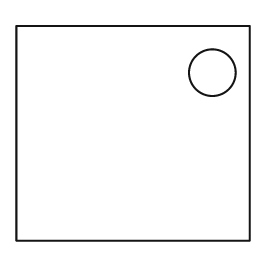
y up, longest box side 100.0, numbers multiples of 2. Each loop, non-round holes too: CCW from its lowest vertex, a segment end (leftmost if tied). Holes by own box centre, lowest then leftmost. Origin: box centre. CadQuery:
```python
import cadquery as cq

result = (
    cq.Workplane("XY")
    .moveTo(-50.0, -46.0)
    .lineTo(50.0, -46.0)
    .lineTo(50.0, 46.0)
    .lineTo(-50.0, 46.0)
    .close()
    .moveTo(34.0, 26.0)
    .circle(10.0)
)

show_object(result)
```